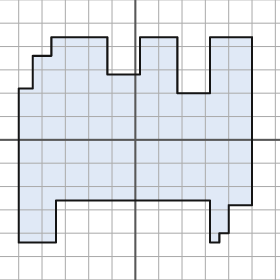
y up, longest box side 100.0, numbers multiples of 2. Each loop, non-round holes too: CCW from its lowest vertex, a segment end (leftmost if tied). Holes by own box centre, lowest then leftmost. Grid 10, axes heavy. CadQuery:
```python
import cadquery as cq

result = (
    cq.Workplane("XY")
    .moveTo(-50.0, -44.0)
    .lineTo(-34.0, -44.0)
    .lineTo(-34.0, -26.0)
    .lineTo(32.0, -26.0)
    .lineTo(32.0, -44.0)
    .lineTo(36.0, -44.0)
    .lineTo(36.0, -40.0)
    .lineTo(40.0, -40.0)
    .lineTo(40.0, -28.0)
    .lineTo(50.0, -28.0)
    .lineTo(50.0, 44.0)
    .lineTo(32.0, 44.0)
    .lineTo(32.0, 20.0)
    .lineTo(18.0, 20.0)
    .lineTo(18.0, 44.0)
    .lineTo(2.0, 44.0)
    .lineTo(2.0, 28.0)
    .lineTo(-12.0, 28.0)
    .lineTo(-12.0, 44.0)
    .lineTo(-36.0, 44.0)
    .lineTo(-36.0, 36.0)
    .lineTo(-44.0, 36.0)
    .lineTo(-44.0, 22.0)
    .lineTo(-50.0, 22.0)
    .close()
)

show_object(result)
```